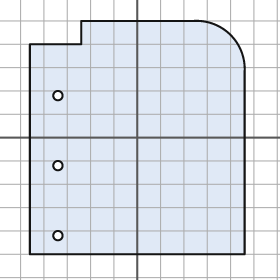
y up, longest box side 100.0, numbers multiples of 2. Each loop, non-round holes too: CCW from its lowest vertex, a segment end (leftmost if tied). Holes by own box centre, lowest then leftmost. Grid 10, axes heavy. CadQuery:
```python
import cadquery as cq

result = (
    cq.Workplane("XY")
    .moveTo(-46.0, -50.0)
    .lineTo(46.0, -50.0)
    .lineTo(46.0, 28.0)
    .threePointArc((40.0, 44.0), (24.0, 50.0))
    .lineTo(-24.0, 50.0)
    .lineTo(-24.0, 40.0)
    .lineTo(-46.0, 40.0)
    .close()
    .moveTo(-34.0, -42.0)
    .circle(2.0)
    .moveTo(-34.0, -12.0)
    .circle(2.0)
    .moveTo(-34.0, 18.0)
    .circle(2.0)
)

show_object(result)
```